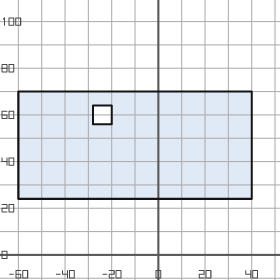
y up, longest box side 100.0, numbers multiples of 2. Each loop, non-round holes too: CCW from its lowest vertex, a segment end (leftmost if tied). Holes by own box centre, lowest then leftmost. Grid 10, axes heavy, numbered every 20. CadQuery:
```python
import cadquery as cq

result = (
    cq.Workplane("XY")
    .moveTo(-60.0, 24.0)
    .lineTo(40.0, 24.0)
    .lineTo(40.0, 70.0)
    .lineTo(-60.0, 70.0)
    .close()
    .moveTo(-28.0, 56.0)
    .lineTo(-20.0, 56.0)
    .lineTo(-20.0, 64.0)
    .lineTo(-28.0, 64.0)
    .close()
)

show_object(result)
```